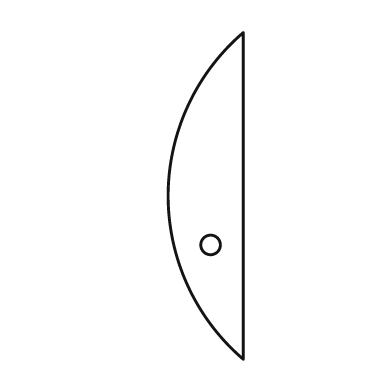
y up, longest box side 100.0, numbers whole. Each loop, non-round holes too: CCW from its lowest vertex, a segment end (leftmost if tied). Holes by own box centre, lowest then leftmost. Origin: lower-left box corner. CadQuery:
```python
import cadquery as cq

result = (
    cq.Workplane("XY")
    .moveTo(23.0, 0.0)
    .lineTo(23.0, 100.0)
    .threePointArc((0.0, 50.0), (23.0, 0.0))
    .close()
    .moveTo(13.0, 35.0)
    .circle(3.0)
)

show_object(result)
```